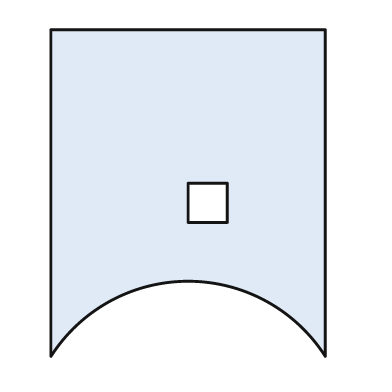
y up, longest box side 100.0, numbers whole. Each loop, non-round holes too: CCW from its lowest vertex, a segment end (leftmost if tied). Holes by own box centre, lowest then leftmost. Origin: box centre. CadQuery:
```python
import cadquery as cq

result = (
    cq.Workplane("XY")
    .moveTo(-42.0, -50.0)
    .threePointArc((0.0, -27.0), (42.0, -50.0))
    .lineTo(42.0, 50.0)
    .lineTo(-42.0, 50.0)
    .close()
    .moveTo(0.0, -9.0)
    .lineTo(12.0, -9.0)
    .lineTo(12.0, 3.0)
    .lineTo(0.0, 3.0)
    .close()
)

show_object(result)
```